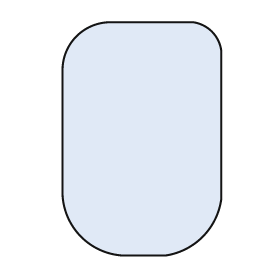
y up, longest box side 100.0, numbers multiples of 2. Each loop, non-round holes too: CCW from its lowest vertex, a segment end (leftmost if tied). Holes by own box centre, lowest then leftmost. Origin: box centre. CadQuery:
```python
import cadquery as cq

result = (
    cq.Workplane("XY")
    .moveTo(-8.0, -50.0)
    .lineTo(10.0, -50.0)
    .threePointArc((26.0, -42.0), (34.0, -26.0))
    .lineTo(34.0, 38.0)
    .threePointArc((30.0, 46.0), (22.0, 50.0))
    .lineTo(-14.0, 50.0)
    .threePointArc((-28.0, 44.0), (-34.0, 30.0))
    .lineTo(-34.0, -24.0)
    .threePointArc((-26.0, -42.0), (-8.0, -50.0))
    .close()
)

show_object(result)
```